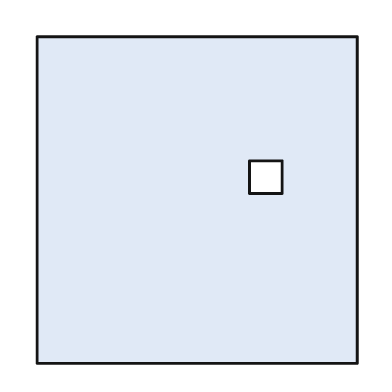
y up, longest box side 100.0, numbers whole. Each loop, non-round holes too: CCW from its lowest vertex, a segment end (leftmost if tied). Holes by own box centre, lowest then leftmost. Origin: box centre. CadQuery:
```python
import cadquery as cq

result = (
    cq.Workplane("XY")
    .moveTo(-49.0, -50.0)
    .lineTo(49.0, -50.0)
    .lineTo(49.0, 50.0)
    .lineTo(-49.0, 50.0)
    .close()
    .moveTo(16.0, 2.0)
    .lineTo(26.0, 2.0)
    .lineTo(26.0, 12.0)
    .lineTo(16.0, 12.0)
    .close()
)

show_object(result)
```